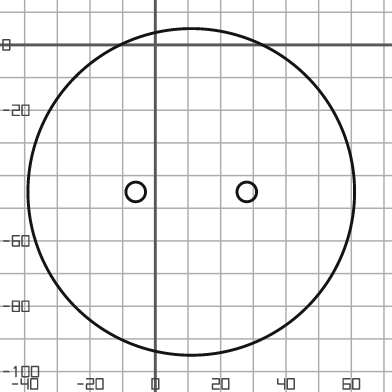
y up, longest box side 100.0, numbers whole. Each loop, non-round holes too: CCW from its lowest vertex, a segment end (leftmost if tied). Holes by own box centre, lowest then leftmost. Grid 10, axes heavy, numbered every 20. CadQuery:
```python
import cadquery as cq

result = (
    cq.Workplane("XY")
    .moveTo(11.0, -45.0)
    .circle(50.0)
    .moveTo(-6.0, -45.0)
    .circle(3.0)
    .moveTo(28.0, -45.0)
    .circle(3.0)
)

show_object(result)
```